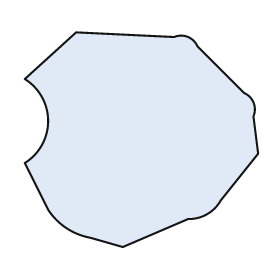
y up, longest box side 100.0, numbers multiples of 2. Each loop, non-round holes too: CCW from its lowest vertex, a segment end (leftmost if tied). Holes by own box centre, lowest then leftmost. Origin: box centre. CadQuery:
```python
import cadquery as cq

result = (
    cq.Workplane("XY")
    .moveTo(-8.0, -46.0)
    .lineTo(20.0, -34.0)
    .threePointArc((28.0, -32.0), (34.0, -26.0))
    .lineTo(50.0, -6.0)
    .lineTo(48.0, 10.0)
    .threePointArc((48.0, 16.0), (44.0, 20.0))
    .lineTo(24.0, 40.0)
    .threePointArc((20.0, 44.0), (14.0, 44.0))
    .lineTo(-28.0, 46.0)
    .lineTo(-50.0, 26.0)
    .threePointArc((-40.0, 8.0), (-50.0, -10.0))
    .lineTo(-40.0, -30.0)
    .threePointArc((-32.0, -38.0), (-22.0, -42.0))
    .close()
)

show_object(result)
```